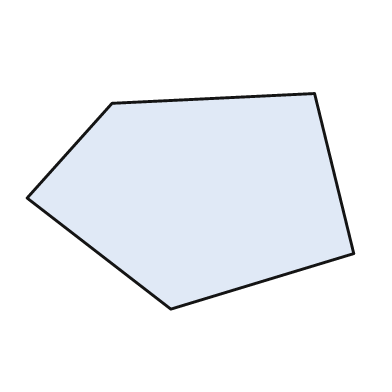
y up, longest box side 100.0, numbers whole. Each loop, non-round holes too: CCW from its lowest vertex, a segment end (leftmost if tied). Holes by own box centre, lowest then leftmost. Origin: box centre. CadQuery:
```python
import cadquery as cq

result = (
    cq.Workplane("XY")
    .moveTo(-6.0, -33.0)
    .lineTo(50.0, -16.0)
    .lineTo(38.0, 33.0)
    .lineTo(-24.0, 30.0)
    .lineTo(-50.0, 1.0)
    .close()
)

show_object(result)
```